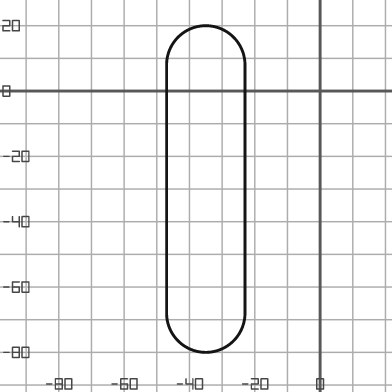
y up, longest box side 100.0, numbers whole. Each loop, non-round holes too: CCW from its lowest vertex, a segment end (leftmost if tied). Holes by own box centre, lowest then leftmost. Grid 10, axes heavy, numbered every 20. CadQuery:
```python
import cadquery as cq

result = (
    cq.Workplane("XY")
    .moveTo(-47.0, -68.0)
    .threePointArc((-35.0, -80.0), (-23.0, -68.0))
    .lineTo(-23.0, 8.0)
    .threePointArc((-35.0, 20.0), (-47.0, 8.0))
    .close()
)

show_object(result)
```